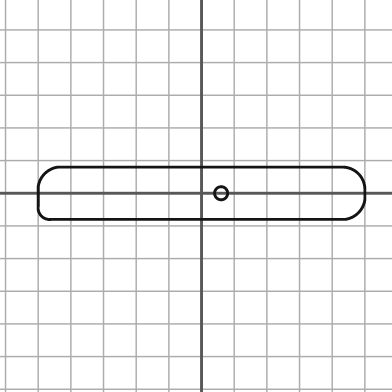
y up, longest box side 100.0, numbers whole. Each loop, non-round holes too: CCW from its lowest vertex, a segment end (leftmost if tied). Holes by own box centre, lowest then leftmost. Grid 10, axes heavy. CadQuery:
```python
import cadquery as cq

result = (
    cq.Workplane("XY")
    .moveTo(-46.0, -8.0)
    .lineTo(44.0, -8.0)
    .threePointArc((48.0, -6.0), (50.0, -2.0))
    .lineTo(50.0, 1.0)
    .threePointArc((48.0, 6.0), (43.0, 8.0))
    .lineTo(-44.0, 8.0)
    .threePointArc((-48.0, 6.0), (-50.0, 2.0))
    .lineTo(-50.0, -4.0)
    .threePointArc((-49.0, -7.0), (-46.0, -8.0))
    .close()
    .moveTo(6.0, 0.0)
    .circle(2.0)
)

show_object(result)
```